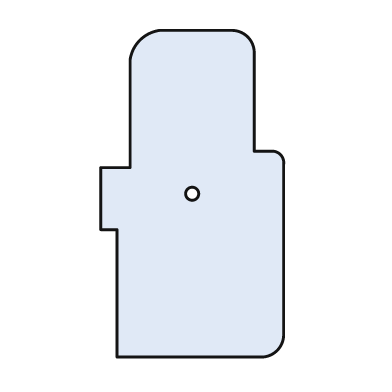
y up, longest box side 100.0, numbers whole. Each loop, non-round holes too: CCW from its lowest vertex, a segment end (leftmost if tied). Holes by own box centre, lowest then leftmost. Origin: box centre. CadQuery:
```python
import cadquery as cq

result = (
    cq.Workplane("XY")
    .moveTo(-23.0, -50.0)
    .lineTo(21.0, -50.0)
    .threePointArc((26.0, -48.0), (28.0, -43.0))
    .lineTo(28.0, 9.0)
    .threePointArc((27.0, 12.0), (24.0, 13.0))
    .lineTo(19.0, 13.0)
    .lineTo(19.0, 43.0)
    .threePointArc((17.0, 48.0), (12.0, 50.0))
    .lineTo(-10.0, 50.0)
    .threePointArc((-16.0, 47.0), (-19.0, 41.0))
    .lineTo(-19.0, 8.0)
    .lineTo(-28.0, 8.0)
    .lineTo(-28.0, -11.0)
    .lineTo(-23.0, -11.0)
    .close()
    .moveTo(0.0, 0.0)
    .circle(2.0)
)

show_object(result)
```